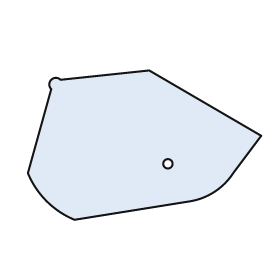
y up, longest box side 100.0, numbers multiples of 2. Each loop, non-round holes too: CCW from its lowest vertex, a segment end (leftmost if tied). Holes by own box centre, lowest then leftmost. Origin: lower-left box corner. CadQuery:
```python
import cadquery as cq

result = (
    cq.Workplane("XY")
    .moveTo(20.0, 0.0)
    .lineTo(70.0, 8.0)
    .threePointArc((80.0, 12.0), (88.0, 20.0))
    .lineTo(100.0, 36.0)
    .lineTo(52.0, 64.0)
    .lineTo(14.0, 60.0)
    .threePointArc((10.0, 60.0), (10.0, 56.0))
    .lineTo(0.0, 20.0)
    .threePointArc((8.0, 8.0), (20.0, 0.0))
    .close()
    .moveTo(60.0, 24.0)
    .circle(2.0)
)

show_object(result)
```